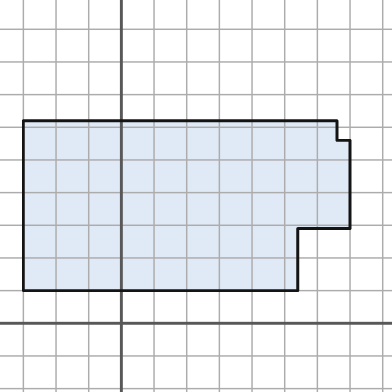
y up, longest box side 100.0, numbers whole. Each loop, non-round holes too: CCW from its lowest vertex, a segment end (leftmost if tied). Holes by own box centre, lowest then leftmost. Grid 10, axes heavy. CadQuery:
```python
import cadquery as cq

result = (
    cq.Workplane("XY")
    .moveTo(-30.0, 10.0)
    .lineTo(54.0, 10.0)
    .lineTo(54.0, 29.0)
    .lineTo(70.0, 29.0)
    .lineTo(70.0, 56.0)
    .lineTo(66.0, 56.0)
    .lineTo(66.0, 62.0)
    .lineTo(-30.0, 62.0)
    .close()
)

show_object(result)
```